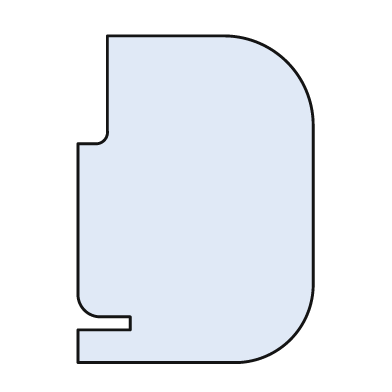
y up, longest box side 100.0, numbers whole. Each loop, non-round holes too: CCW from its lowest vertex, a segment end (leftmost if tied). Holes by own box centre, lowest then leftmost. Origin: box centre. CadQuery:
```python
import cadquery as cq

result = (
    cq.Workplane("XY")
    .moveTo(-36.0, -50.0)
    .lineTo(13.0, -50.0)
    .threePointArc((29.0, -43.0), (36.0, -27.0))
    .lineTo(36.0, 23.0)
    .threePointArc((28.0, 42.0), (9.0, 50.0))
    .lineTo(-27.0, 50.0)
    .lineTo(-27.0, 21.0)
    .threePointArc((-28.0, 18.0), (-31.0, 17.0))
    .lineTo(-36.0, 17.0)
    .lineTo(-36.0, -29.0)
    .threePointArc((-34.0, -34.0), (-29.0, -36.0))
    .lineTo(-20.0, -36.0)
    .lineTo(-20.0, -40.0)
    .lineTo(-36.0, -40.0)
    .close()
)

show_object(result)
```